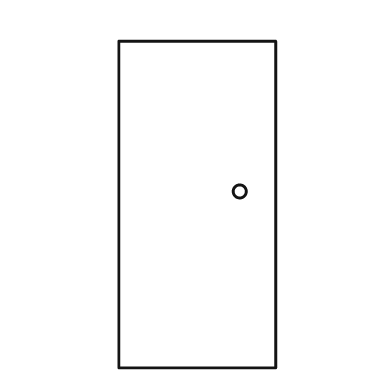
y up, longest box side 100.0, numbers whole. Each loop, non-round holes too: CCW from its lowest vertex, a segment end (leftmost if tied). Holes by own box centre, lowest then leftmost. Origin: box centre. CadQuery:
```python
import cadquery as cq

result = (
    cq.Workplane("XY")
    .moveTo(-24.0, -50.0)
    .lineTo(24.0, -50.0)
    .lineTo(24.0, 50.0)
    .lineTo(-24.0, 50.0)
    .close()
    .moveTo(13.0, 4.0)
    .circle(2.0)
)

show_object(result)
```